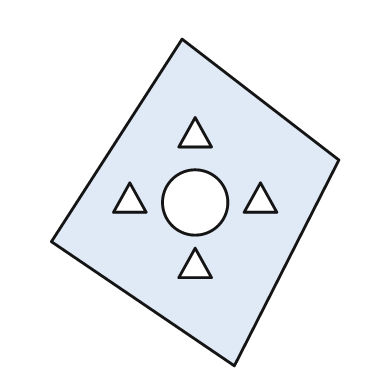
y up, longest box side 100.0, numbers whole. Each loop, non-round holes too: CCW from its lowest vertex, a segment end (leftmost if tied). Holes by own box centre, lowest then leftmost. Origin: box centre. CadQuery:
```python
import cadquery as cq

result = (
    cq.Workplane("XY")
    .moveTo(12.0, -50.0)
    .lineTo(44.0, 13.0)
    .lineTo(-4.0, 50.0)
    .lineTo(-44.0, -12.0)
    .close()
    .moveTo(-5.0, -23.0)
    .lineTo(5.0, -23.0)
    .lineTo(0.0, -14.0)
    .close()
    .moveTo(0.0, 0.0)
    .circle(10.0)
    .moveTo(-25.0, -3.0)
    .lineTo(-15.0, -3.0)
    .lineTo(-20.0, 6.0)
    .close()
    .moveTo(15.0, -3.0)
    .lineTo(25.0, -3.0)
    .lineTo(20.0, 6.0)
    .close()
    .moveTo(-5.0, 17.0)
    .lineTo(5.0, 17.0)
    .lineTo(0.0, 26.0)
    .close()
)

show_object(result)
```